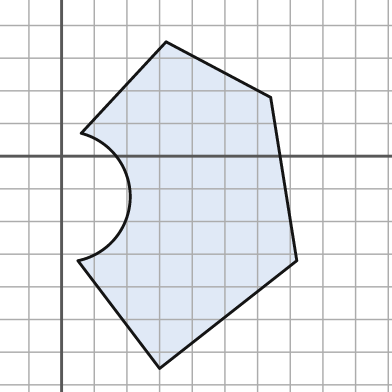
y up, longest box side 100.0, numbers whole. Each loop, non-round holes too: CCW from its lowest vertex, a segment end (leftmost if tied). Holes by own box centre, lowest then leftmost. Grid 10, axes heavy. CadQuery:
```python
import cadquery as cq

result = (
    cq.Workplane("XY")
    .moveTo(30.0, -65.0)
    .lineTo(72.0, -32.0)
    .lineTo(64.0, 18.0)
    .lineTo(32.0, 35.0)
    .lineTo(6.0, 7.0)
    .threePointArc((21.0, -13.0), (5.0, -32.0))
    .close()
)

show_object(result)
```